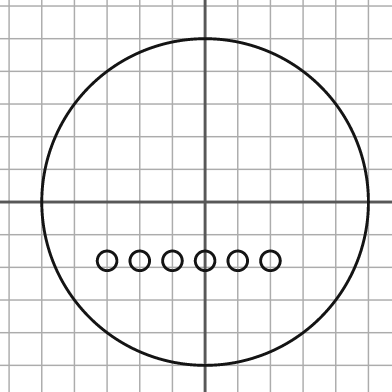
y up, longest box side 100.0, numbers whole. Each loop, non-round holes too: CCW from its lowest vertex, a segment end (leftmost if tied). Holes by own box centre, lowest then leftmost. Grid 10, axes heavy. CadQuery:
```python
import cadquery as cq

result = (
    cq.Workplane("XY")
    .moveTo(0.0, 0.0)
    .circle(50.0)
    .moveTo(-30.0, -18.0)
    .circle(3.0)
    .moveTo(-20.0, -18.0)
    .circle(3.0)
    .moveTo(-10.0, -18.0)
    .circle(3.0)
    .moveTo(0.0, -18.0)
    .circle(3.0)
    .moveTo(10.0, -18.0)
    .circle(3.0)
    .moveTo(20.0, -18.0)
    .circle(3.0)
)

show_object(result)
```